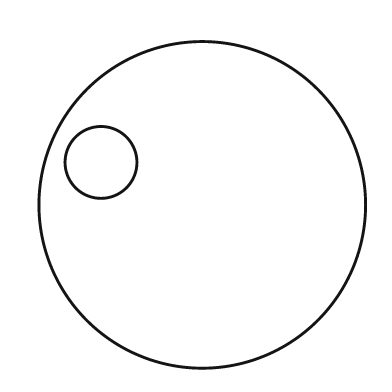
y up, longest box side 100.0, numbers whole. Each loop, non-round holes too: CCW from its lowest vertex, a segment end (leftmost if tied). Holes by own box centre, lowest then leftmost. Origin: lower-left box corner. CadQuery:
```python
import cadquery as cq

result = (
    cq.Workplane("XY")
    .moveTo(50.0, 50.0)
    .circle(50.0)
    .moveTo(19.0, 63.0)
    .circle(11.0)
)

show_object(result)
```